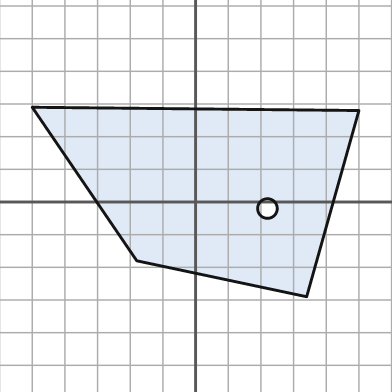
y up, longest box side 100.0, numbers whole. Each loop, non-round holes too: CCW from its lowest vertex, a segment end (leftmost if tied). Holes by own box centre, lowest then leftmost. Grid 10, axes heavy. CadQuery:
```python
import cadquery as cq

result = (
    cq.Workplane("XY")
    .moveTo(34.0, -29.0)
    .lineTo(50.0, 28.0)
    .lineTo(-50.0, 29.0)
    .lineTo(-18.0, -18.0)
    .close()
    .moveTo(22.0, -2.0)
    .circle(3.0)
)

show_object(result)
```